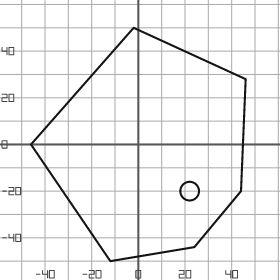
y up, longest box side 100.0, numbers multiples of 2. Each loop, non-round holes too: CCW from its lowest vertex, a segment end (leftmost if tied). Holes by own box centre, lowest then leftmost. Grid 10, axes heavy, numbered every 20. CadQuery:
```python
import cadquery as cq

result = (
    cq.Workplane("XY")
    .moveTo(-12.0, -50.0)
    .lineTo(24.0, -44.0)
    .lineTo(44.0, -20.0)
    .lineTo(46.0, 28.0)
    .lineTo(-2.0, 50.0)
    .lineTo(-46.0, 0.0)
    .close()
    .moveTo(22.0, -20.0)
    .circle(4.0)
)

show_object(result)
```